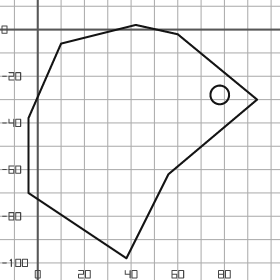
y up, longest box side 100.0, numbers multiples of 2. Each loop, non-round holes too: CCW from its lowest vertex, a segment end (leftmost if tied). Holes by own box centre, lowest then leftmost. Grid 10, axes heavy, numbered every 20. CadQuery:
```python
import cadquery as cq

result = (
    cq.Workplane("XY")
    .moveTo(38.0, -98.0)
    .lineTo(56.0, -62.0)
    .lineTo(94.0, -30.0)
    .lineTo(60.0, -2.0)
    .lineTo(42.0, 2.0)
    .lineTo(10.0, -6.0)
    .lineTo(-4.0, -38.0)
    .lineTo(-4.0, -70.0)
    .close()
    .moveTo(78.0, -28.0)
    .circle(4.0)
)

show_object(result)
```